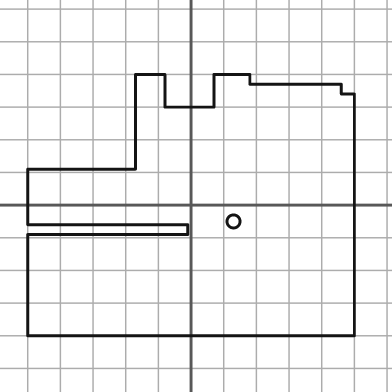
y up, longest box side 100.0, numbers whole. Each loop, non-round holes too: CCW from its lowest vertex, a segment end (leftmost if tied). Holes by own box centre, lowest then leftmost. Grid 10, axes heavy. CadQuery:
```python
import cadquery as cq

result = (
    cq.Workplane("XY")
    .moveTo(-50.0, -40.0)
    .lineTo(50.0, -40.0)
    .lineTo(50.0, 34.0)
    .lineTo(46.0, 34.0)
    .lineTo(46.0, 37.0)
    .lineTo(18.0, 37.0)
    .lineTo(18.0, 40.0)
    .lineTo(7.0, 40.0)
    .lineTo(7.0, 30.0)
    .lineTo(-8.0, 30.0)
    .lineTo(-8.0, 40.0)
    .lineTo(-17.0, 40.0)
    .lineTo(-17.0, 11.0)
    .lineTo(-50.0, 11.0)
    .lineTo(-50.0, -6.0)
    .lineTo(-1.0, -6.0)
    .lineTo(-1.0, -9.0)
    .lineTo(-50.0, -9.0)
    .close()
    .moveTo(13.0, -5.0)
    .circle(2.0)
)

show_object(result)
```